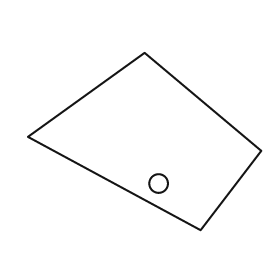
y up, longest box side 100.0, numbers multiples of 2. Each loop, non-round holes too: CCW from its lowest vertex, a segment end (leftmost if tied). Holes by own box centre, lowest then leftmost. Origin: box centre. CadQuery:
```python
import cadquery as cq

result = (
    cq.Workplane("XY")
    .moveTo(24.0, -38.0)
    .lineTo(50.0, -4.0)
    .lineTo(0.0, 38.0)
    .lineTo(-50.0, 2.0)
    .close()
    .moveTo(6.0, -18.0)
    .circle(4.0)
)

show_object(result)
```